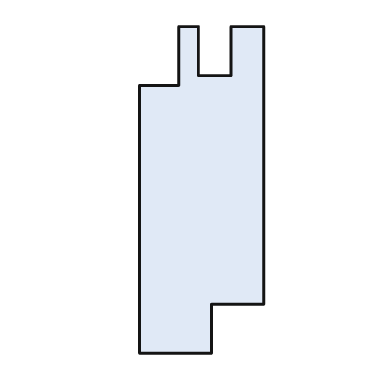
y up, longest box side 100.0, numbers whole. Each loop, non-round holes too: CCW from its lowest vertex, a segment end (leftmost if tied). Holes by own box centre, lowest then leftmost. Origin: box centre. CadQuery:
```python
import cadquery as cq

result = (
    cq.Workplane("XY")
    .moveTo(-19.0, -50.0)
    .lineTo(3.0, -50.0)
    .lineTo(3.0, -35.0)
    .lineTo(19.0, -35.0)
    .lineTo(19.0, 50.0)
    .lineTo(9.0, 50.0)
    .lineTo(9.0, 35.0)
    .lineTo(-1.0, 35.0)
    .lineTo(-1.0, 50.0)
    .lineTo(-7.0, 50.0)
    .lineTo(-7.0, 32.0)
    .lineTo(-19.0, 32.0)
    .close()
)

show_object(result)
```